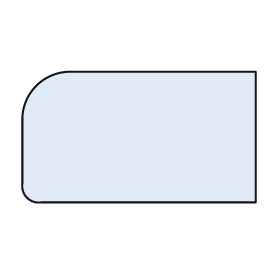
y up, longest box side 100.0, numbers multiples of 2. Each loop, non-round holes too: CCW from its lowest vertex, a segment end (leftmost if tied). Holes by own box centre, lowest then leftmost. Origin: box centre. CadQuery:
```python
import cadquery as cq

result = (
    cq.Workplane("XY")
    .moveTo(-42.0, -28.0)
    .lineTo(50.0, -28.0)
    .lineTo(50.0, 28.0)
    .lineTo(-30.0, 28.0)
    .threePointArc((-44.0, 22.0), (-50.0, 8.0))
    .lineTo(-50.0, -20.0)
    .threePointArc((-48.0, -26.0), (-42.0, -28.0))
    .close()
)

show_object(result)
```